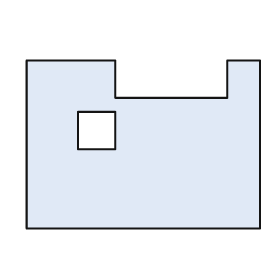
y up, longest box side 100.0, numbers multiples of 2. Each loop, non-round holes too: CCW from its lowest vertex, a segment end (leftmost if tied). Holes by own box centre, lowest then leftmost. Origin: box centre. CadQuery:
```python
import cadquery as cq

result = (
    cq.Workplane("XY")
    .moveTo(-50.0, -36.0)
    .lineTo(50.0, -36.0)
    .lineTo(50.0, 36.0)
    .lineTo(36.0, 36.0)
    .lineTo(36.0, 20.0)
    .lineTo(-12.0, 20.0)
    .lineTo(-12.0, 36.0)
    .lineTo(-50.0, 36.0)
    .close()
    .moveTo(-28.0, -2.0)
    .lineTo(-12.0, -2.0)
    .lineTo(-12.0, 14.0)
    .lineTo(-28.0, 14.0)
    .close()
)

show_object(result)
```